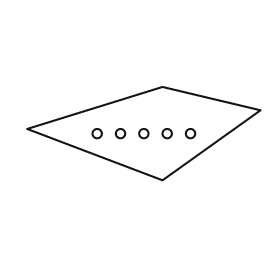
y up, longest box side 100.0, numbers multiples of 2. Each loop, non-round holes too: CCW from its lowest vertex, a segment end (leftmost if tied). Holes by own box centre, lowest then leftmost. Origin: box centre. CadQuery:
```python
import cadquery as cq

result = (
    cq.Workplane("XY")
    .moveTo(8.0, -20.0)
    .lineTo(50.0, 10.0)
    .lineTo(8.0, 20.0)
    .lineTo(-50.0, 2.0)
    .close()
    .moveTo(-20.0, 0.0)
    .circle(2.0)
    .moveTo(-10.0, 0.0)
    .circle(2.0)
    .moveTo(0.0, 0.0)
    .circle(2.0)
    .moveTo(10.0, 0.0)
    .circle(2.0)
    .moveTo(20.0, 0.0)
    .circle(2.0)
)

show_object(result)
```